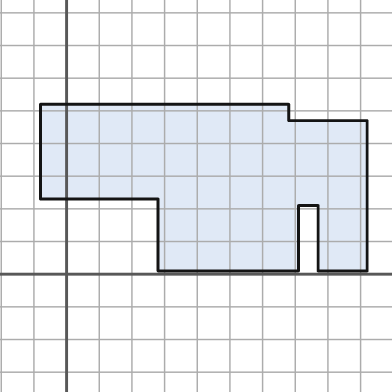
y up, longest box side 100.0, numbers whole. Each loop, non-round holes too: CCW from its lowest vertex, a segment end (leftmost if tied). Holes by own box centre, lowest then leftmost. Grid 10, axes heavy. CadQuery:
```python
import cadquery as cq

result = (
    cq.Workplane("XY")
    .moveTo(28.0, 1.0)
    .lineTo(71.0, 1.0)
    .lineTo(71.0, 21.0)
    .lineTo(77.0, 21.0)
    .lineTo(77.0, 1.0)
    .lineTo(92.0, 1.0)
    .lineTo(92.0, 47.0)
    .lineTo(68.0, 47.0)
    .lineTo(68.0, 52.0)
    .lineTo(-8.0, 52.0)
    .lineTo(-8.0, 23.0)
    .lineTo(28.0, 23.0)
    .close()
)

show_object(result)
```